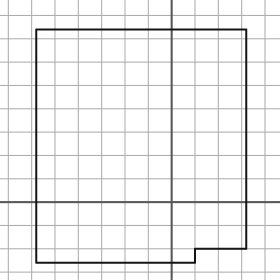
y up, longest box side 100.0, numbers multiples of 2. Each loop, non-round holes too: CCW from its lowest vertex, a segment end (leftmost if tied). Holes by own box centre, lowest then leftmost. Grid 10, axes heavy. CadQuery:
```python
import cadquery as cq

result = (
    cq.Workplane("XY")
    .moveTo(-58.0, -26.0)
    .lineTo(10.0, -26.0)
    .lineTo(10.0, -20.0)
    .lineTo(32.0, -20.0)
    .lineTo(32.0, 74.0)
    .lineTo(-58.0, 74.0)
    .close()
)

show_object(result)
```